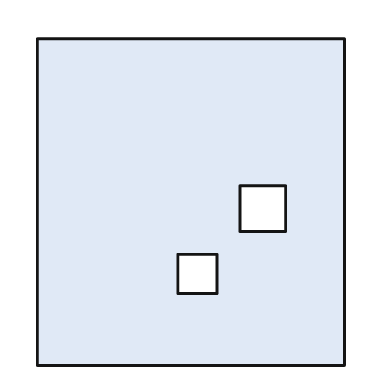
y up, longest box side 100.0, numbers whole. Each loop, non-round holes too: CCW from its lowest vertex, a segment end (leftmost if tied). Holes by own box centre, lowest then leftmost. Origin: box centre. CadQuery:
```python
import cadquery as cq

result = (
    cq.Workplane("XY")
    .moveTo(-47.0, -50.0)
    .lineTo(47.0, -50.0)
    .lineTo(47.0, 50.0)
    .lineTo(-47.0, 50.0)
    .close()
    .moveTo(-4.0, -28.0)
    .lineTo(8.0, -28.0)
    .lineTo(8.0, -16.0)
    .lineTo(-4.0, -16.0)
    .close()
    .moveTo(15.0, -9.0)
    .lineTo(29.0, -9.0)
    .lineTo(29.0, 5.0)
    .lineTo(15.0, 5.0)
    .close()
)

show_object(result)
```